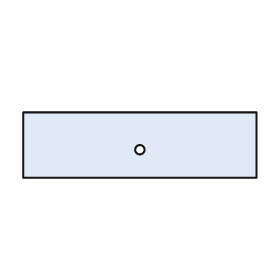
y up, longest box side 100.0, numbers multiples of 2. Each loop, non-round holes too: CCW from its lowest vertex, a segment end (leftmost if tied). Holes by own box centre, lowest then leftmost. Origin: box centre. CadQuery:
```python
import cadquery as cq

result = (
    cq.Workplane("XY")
    .moveTo(-50.0, -14.0)
    .lineTo(50.0, -14.0)
    .lineTo(50.0, 14.0)
    .lineTo(-50.0, 14.0)
    .close()
    .moveTo(0.0, -2.0)
    .circle(2.0)
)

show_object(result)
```